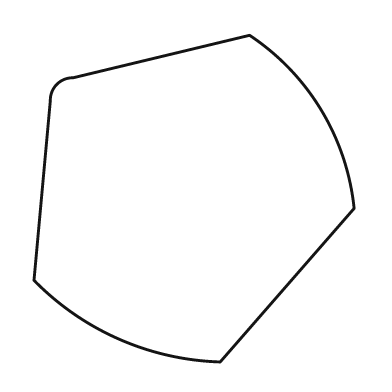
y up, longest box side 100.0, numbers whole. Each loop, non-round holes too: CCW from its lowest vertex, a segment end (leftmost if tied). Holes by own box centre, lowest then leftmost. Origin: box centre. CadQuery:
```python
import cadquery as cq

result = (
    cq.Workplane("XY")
    .moveTo(8.0, -50.0)
    .lineTo(49.0, -3.0)
    .threePointArc((39.0, 27.0), (17.0, 50.0))
    .lineTo(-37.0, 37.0)
    .threePointArc((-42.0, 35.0), (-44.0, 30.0))
    .lineTo(-49.0, -25.0)
    .threePointArc((-23.0, -43.0), (8.0, -50.0))
    .close()
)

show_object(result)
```